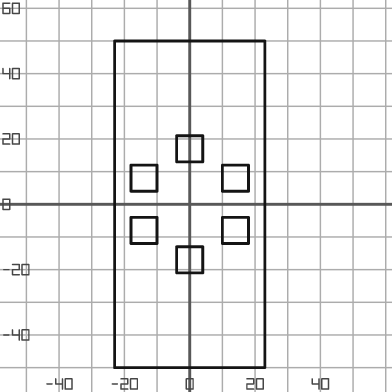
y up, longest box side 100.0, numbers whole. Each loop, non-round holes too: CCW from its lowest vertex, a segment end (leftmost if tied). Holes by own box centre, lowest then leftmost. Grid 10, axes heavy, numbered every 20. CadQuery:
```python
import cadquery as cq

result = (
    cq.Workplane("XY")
    .moveTo(-23.0, -50.0)
    .lineTo(23.0, -50.0)
    .lineTo(23.0, 50.0)
    .lineTo(-23.0, 50.0)
    .close()
    .moveTo(-4.0, -21.0)
    .lineTo(4.0, -21.0)
    .lineTo(4.0, -13.0)
    .lineTo(-4.0, -13.0)
    .close()
    .moveTo(-18.0, -12.0)
    .lineTo(-10.0, -12.0)
    .lineTo(-10.0, -4.0)
    .lineTo(-18.0, -4.0)
    .close()
    .moveTo(10.0, -12.0)
    .lineTo(18.0, -12.0)
    .lineTo(18.0, -4.0)
    .lineTo(10.0, -4.0)
    .close()
    .moveTo(-18.0, 4.0)
    .lineTo(-10.0, 4.0)
    .lineTo(-10.0, 12.0)
    .lineTo(-18.0, 12.0)
    .close()
    .moveTo(10.0, 4.0)
    .lineTo(18.0, 4.0)
    .lineTo(18.0, 12.0)
    .lineTo(10.0, 12.0)
    .close()
    .moveTo(-4.0, 13.0)
    .lineTo(4.0, 13.0)
    .lineTo(4.0, 21.0)
    .lineTo(-4.0, 21.0)
    .close()
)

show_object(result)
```